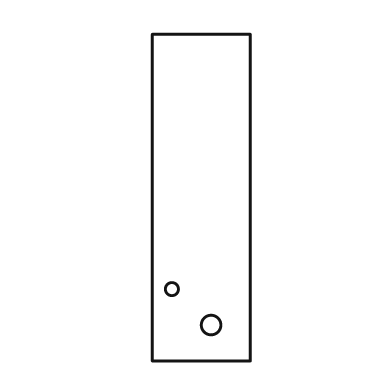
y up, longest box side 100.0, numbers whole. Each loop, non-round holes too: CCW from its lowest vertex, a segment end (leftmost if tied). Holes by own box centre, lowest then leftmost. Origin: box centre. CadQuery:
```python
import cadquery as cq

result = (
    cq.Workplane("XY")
    .moveTo(-15.0, -50.0)
    .lineTo(15.0, -50.0)
    .lineTo(15.0, 50.0)
    .lineTo(-15.0, 50.0)
    .close()
    .moveTo(3.0, -39.0)
    .circle(3.0)
    .moveTo(-9.0, -28.0)
    .circle(2.0)
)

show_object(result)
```